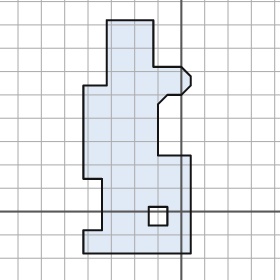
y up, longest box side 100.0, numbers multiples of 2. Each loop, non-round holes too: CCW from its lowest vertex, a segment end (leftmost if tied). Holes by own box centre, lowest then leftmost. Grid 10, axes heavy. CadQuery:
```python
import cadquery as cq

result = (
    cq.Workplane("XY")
    .moveTo(-42.0, -18.0)
    .lineTo(4.0, -18.0)
    .lineTo(4.0, 24.0)
    .lineTo(-10.0, 24.0)
    .lineTo(-10.0, 46.0)
    .lineTo(-6.0, 50.0)
    .lineTo(0.0, 50.0)
    .lineTo(4.0, 54.0)
    .lineTo(4.0, 58.0)
    .lineTo(0.0, 62.0)
    .lineTo(-12.0, 62.0)
    .lineTo(-12.0, 82.0)
    .lineTo(-32.0, 82.0)
    .lineTo(-32.0, 54.0)
    .lineTo(-42.0, 54.0)
    .lineTo(-42.0, 14.0)
    .lineTo(-34.0, 14.0)
    .lineTo(-34.0, -8.0)
    .lineTo(-42.0, -8.0)
    .close()
    .moveTo(-14.0, -6.0)
    .lineTo(-6.0, -6.0)
    .lineTo(-6.0, 2.0)
    .lineTo(-14.0, 2.0)
    .close()
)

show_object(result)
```